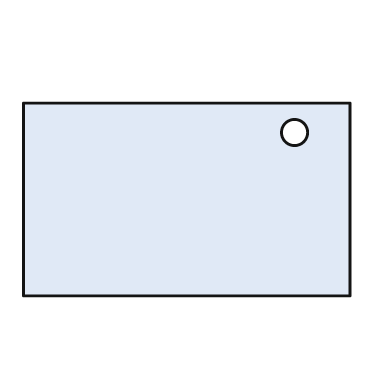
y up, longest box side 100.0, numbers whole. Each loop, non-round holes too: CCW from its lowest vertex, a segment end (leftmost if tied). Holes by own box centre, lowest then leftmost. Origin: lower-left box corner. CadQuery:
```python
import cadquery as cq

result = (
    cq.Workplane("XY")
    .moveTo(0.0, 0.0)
    .lineTo(100.0, 0.0)
    .lineTo(100.0, 59.0)
    .lineTo(0.0, 59.0)
    .close()
    .moveTo(83.0, 50.0)
    .circle(4.0)
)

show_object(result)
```